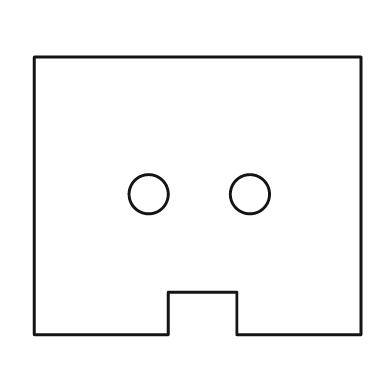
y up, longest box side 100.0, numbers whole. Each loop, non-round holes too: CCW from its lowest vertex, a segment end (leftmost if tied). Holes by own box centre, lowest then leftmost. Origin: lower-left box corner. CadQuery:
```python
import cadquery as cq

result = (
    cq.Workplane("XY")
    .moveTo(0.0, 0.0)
    .lineTo(41.0, 0.0)
    .lineTo(41.0, 13.0)
    .lineTo(62.0, 13.0)
    .lineTo(62.0, 0.0)
    .lineTo(100.0, 0.0)
    .lineTo(100.0, 85.0)
    .lineTo(0.0, 85.0)
    .close()
    .moveTo(35.0, 43.0)
    .circle(6.0)
    .moveTo(66.0, 43.0)
    .circle(6.0)
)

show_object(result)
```